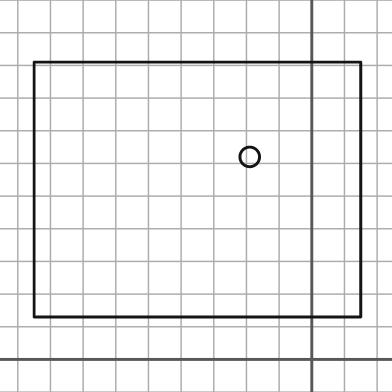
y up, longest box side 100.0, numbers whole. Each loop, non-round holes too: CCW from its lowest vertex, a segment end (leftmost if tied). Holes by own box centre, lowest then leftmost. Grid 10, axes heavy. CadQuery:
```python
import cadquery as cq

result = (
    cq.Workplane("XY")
    .moveTo(-85.0, 13.0)
    .lineTo(15.0, 13.0)
    .lineTo(15.0, 91.0)
    .lineTo(-85.0, 91.0)
    .close()
    .moveTo(-19.0, 62.0)
    .circle(3.0)
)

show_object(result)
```